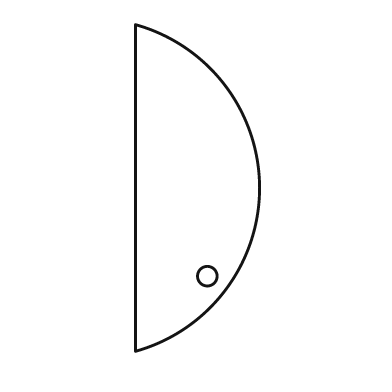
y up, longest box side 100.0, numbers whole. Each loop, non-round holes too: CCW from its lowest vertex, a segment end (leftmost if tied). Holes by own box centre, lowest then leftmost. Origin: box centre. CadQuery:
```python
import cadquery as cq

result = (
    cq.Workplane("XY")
    .moveTo(-19.0, -50.0)
    .threePointArc((19.0, 0.0), (-19.0, 50.0))
    .close()
    .moveTo(3.0, -27.0)
    .circle(3.0)
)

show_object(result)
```